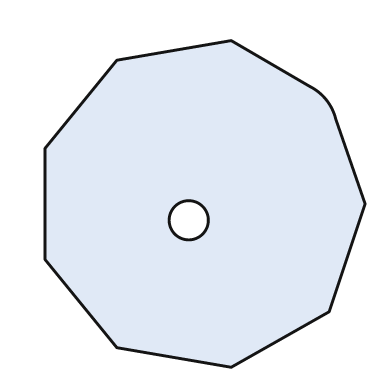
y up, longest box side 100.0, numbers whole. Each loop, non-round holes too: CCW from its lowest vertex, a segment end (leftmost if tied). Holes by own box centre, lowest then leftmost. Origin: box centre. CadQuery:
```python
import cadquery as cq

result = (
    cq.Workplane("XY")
    .moveTo(8.0, -50.0)
    .lineTo(38.0, -33.0)
    .lineTo(49.0, 0.0)
    .lineTo(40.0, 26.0)
    .threePointArc((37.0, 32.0), (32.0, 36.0))
    .lineTo(8.0, 50.0)
    .lineTo(-27.0, 44.0)
    .lineTo(-49.0, 17.0)
    .lineTo(-49.0, -17.0)
    .lineTo(-27.0, -44.0)
    .close()
    .moveTo(-5.0, -5.0)
    .circle(6.0)
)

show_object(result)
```